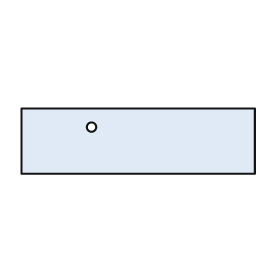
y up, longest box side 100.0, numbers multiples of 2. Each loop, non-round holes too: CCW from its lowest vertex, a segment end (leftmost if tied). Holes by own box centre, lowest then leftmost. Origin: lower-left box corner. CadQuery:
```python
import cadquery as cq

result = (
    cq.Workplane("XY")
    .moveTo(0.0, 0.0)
    .lineTo(100.0, 0.0)
    .lineTo(100.0, 28.0)
    .lineTo(0.0, 28.0)
    .close()
    .moveTo(30.0, 20.0)
    .circle(2.0)
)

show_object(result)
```